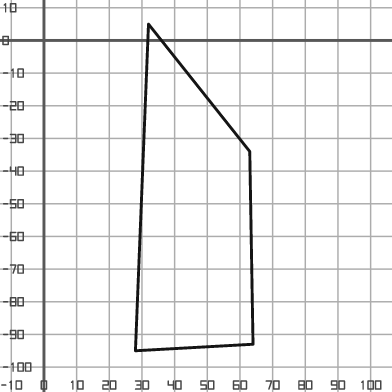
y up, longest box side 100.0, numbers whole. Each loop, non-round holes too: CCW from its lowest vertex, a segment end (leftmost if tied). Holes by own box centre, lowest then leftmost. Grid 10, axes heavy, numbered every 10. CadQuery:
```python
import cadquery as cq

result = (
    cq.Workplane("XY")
    .moveTo(28.0, -95.0)
    .lineTo(64.0, -93.0)
    .lineTo(63.0, -34.0)
    .lineTo(32.0, 5.0)
    .close()
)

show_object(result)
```